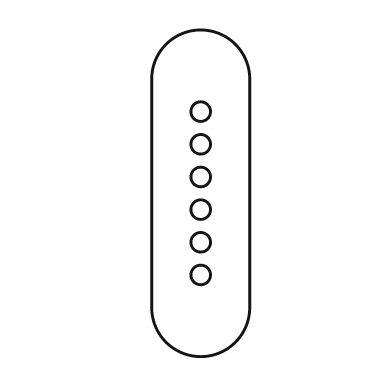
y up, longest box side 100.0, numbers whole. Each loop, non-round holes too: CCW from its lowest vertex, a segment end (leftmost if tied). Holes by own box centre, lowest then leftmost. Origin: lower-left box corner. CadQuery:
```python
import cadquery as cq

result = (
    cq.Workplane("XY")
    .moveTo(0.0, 15.0)
    .threePointArc((15.0, 0.0), (30.0, 15.0))
    .lineTo(30.0, 85.0)
    .threePointArc((15.0, 100.0), (0.0, 85.0))
    .close()
    .moveTo(15.0, 25.0)
    .circle(3.0)
    .moveTo(15.0, 35.0)
    .circle(3.0)
    .moveTo(15.0, 45.0)
    .circle(3.0)
    .moveTo(15.0, 55.0)
    .circle(3.0)
    .moveTo(15.0, 65.0)
    .circle(3.0)
    .moveTo(15.0, 75.0)
    .circle(3.0)
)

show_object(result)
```